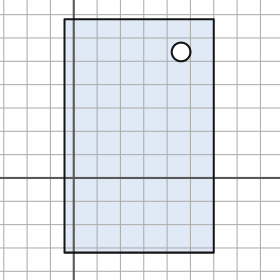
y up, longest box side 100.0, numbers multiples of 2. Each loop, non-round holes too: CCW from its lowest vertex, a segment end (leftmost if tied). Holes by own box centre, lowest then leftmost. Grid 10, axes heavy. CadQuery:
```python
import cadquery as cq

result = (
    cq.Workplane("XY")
    .moveTo(-4.0, -32.0)
    .lineTo(60.0, -32.0)
    .lineTo(60.0, 68.0)
    .lineTo(-4.0, 68.0)
    .close()
    .moveTo(46.0, 54.0)
    .circle(4.0)
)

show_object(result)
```